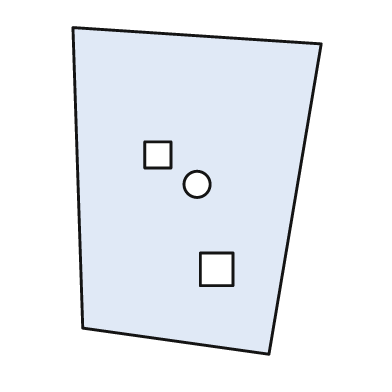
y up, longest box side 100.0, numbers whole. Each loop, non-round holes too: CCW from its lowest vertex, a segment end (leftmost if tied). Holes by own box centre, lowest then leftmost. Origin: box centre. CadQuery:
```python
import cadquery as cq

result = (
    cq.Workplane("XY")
    .moveTo(22.0, -50.0)
    .lineTo(38.0, 45.0)
    .lineTo(-38.0, 50.0)
    .lineTo(-35.0, -42.0)
    .close()
    .moveTo(1.0, -29.0)
    .lineTo(11.0, -29.0)
    .lineTo(11.0, -19.0)
    .lineTo(1.0, -19.0)
    .close()
    .moveTo(0.0, 2.0)
    .circle(4.0)
    .moveTo(-16.0, 7.0)
    .lineTo(-8.0, 7.0)
    .lineTo(-8.0, 15.0)
    .lineTo(-16.0, 15.0)
    .close()
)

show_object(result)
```